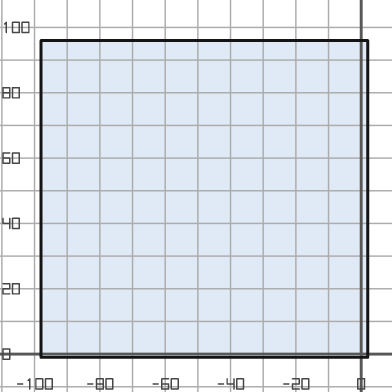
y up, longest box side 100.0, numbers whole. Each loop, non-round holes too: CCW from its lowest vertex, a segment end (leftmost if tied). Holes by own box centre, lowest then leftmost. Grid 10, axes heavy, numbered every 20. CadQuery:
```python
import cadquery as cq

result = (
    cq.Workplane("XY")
    .moveTo(-98.0, -1.0)
    .lineTo(2.0, -1.0)
    .lineTo(2.0, 96.0)
    .lineTo(-98.0, 96.0)
    .close()
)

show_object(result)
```